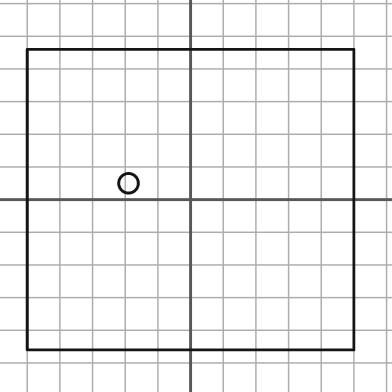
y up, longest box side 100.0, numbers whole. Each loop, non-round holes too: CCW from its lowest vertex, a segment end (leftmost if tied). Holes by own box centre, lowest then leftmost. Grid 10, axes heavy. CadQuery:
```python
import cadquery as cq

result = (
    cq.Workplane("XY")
    .moveTo(-50.0, -46.0)
    .lineTo(50.0, -46.0)
    .lineTo(50.0, 46.0)
    .lineTo(-50.0, 46.0)
    .close()
    .moveTo(-19.0, 5.0)
    .circle(3.0)
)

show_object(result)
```